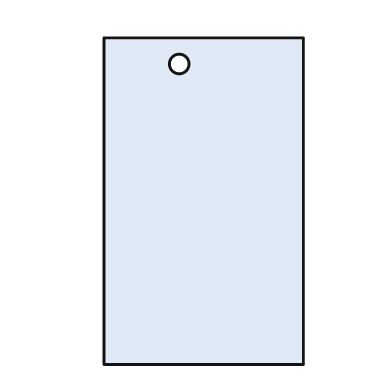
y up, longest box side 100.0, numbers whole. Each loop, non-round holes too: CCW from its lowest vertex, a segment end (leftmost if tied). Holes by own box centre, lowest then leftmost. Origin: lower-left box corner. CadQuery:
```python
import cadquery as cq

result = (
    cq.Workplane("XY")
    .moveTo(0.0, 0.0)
    .lineTo(61.0, 0.0)
    .lineTo(61.0, 100.0)
    .lineTo(0.0, 100.0)
    .close()
    .moveTo(23.0, 92.0)
    .circle(3.0)
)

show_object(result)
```